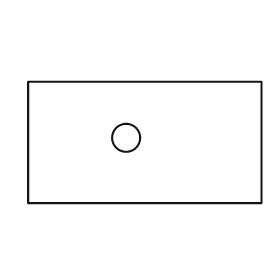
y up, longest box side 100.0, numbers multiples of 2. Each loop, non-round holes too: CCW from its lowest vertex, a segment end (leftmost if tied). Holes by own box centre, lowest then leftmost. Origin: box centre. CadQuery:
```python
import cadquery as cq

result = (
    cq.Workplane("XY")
    .moveTo(-50.0, -26.0)
    .lineTo(50.0, -26.0)
    .lineTo(50.0, 26.0)
    .lineTo(-50.0, 26.0)
    .close()
    .moveTo(-8.0, 2.0)
    .circle(6.0)
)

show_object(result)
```